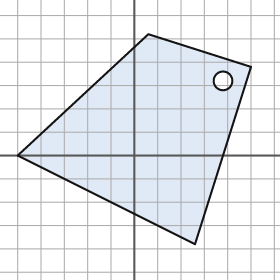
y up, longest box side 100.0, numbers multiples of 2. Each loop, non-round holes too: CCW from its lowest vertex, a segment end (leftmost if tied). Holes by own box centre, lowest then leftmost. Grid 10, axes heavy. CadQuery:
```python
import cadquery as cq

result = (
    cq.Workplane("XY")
    .moveTo(26.0, -38.0)
    .lineTo(50.0, 38.0)
    .lineTo(6.0, 52.0)
    .lineTo(-50.0, 0.0)
    .close()
    .moveTo(38.0, 32.0)
    .circle(4.0)
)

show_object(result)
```